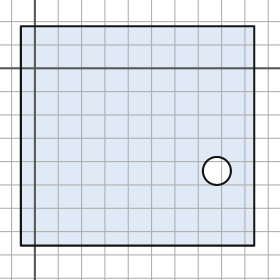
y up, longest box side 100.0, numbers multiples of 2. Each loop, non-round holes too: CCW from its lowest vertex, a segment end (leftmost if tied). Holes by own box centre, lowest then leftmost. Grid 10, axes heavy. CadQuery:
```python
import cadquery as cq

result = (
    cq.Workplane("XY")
    .moveTo(-6.0, -76.0)
    .lineTo(94.0, -76.0)
    .lineTo(94.0, 18.0)
    .lineTo(-6.0, 18.0)
    .close()
    .moveTo(78.0, -44.0)
    .circle(6.0)
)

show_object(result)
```